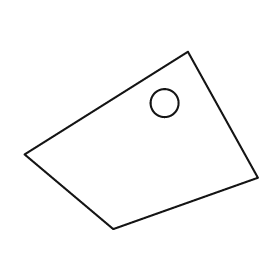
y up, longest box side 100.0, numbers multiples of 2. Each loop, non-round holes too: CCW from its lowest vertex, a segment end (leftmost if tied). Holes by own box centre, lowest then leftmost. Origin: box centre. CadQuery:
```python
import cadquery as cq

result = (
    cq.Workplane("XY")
    .moveTo(-12.0, -38.0)
    .lineTo(50.0, -16.0)
    .lineTo(20.0, 38.0)
    .lineTo(-50.0, -6.0)
    .close()
    .moveTo(10.0, 16.0)
    .circle(6.0)
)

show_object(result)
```